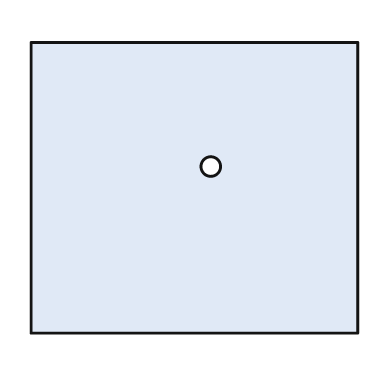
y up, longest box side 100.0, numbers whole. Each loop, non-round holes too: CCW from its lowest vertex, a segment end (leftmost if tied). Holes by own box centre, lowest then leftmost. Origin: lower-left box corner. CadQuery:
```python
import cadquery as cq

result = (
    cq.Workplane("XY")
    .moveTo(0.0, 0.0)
    .lineTo(100.0, 0.0)
    .lineTo(100.0, 89.0)
    .lineTo(0.0, 89.0)
    .close()
    .moveTo(55.0, 51.0)
    .circle(3.0)
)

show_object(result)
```